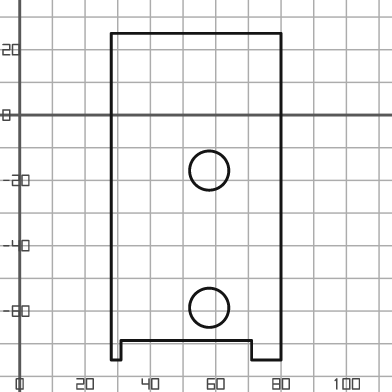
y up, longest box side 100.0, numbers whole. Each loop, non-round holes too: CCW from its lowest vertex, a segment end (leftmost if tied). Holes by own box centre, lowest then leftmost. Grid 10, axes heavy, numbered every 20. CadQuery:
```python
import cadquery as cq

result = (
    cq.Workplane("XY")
    .moveTo(28.0, -75.0)
    .lineTo(31.0, -75.0)
    .lineTo(31.0, -69.0)
    .lineTo(71.0, -69.0)
    .lineTo(71.0, -75.0)
    .lineTo(80.0, -75.0)
    .lineTo(80.0, 25.0)
    .lineTo(28.0, 25.0)
    .close()
    .moveTo(58.0, -59.0)
    .circle(6.0)
    .moveTo(58.0, -17.0)
    .circle(6.0)
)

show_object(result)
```